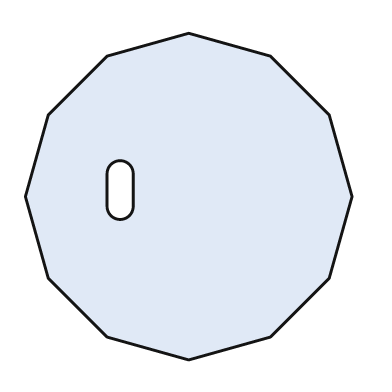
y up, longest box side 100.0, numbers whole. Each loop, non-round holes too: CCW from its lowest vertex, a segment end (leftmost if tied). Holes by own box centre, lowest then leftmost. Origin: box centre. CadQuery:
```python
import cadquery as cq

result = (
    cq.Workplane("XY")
    .moveTo(0.0, -50.0)
    .lineTo(25.0, -43.0)
    .lineTo(43.0, -25.0)
    .lineTo(50.0, 0.0)
    .lineTo(43.0, 25.0)
    .lineTo(25.0, 43.0)
    .lineTo(0.0, 50.0)
    .lineTo(-25.0, 43.0)
    .lineTo(-43.0, 25.0)
    .lineTo(-50.0, 0.0)
    .lineTo(-43.0, -25.0)
    .lineTo(-25.0, -43.0)
    .close()
    .moveTo(-25.0, -3.0)
    .threePointArc((-21.0, -7.0), (-17.0, -3.0))
    .lineTo(-17.0, 7.0)
    .threePointArc((-21.0, 11.0), (-25.0, 7.0))
    .close()
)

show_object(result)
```